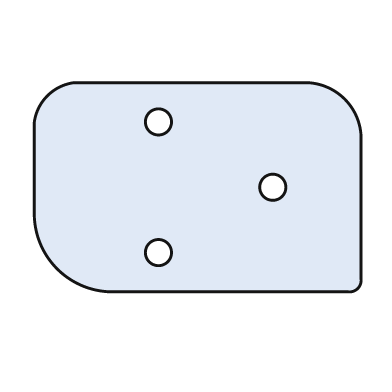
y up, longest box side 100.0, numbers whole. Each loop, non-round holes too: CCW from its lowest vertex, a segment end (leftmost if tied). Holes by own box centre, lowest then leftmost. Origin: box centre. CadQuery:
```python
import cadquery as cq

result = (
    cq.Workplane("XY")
    .moveTo(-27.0, -32.0)
    .lineTo(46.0, -32.0)
    .threePointArc((49.0, -31.0), (50.0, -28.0))
    .lineTo(50.0, 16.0)
    .threePointArc((45.0, 27.0), (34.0, 32.0))
    .lineTo(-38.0, 32.0)
    .threePointArc((-46.0, 28.0), (-50.0, 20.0))
    .lineTo(-50.0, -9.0)
    .threePointArc((-43.0, -25.0), (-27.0, -32.0))
    .close()
    .moveTo(-12.0, -20.0)
    .circle(4.0)
    .moveTo(23.0, 0.0)
    .circle(4.0)
    .moveTo(-12.0, 20.0)
    .circle(4.0)
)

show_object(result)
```